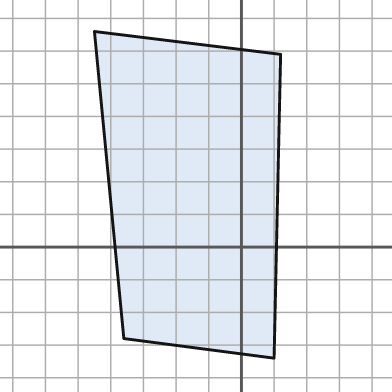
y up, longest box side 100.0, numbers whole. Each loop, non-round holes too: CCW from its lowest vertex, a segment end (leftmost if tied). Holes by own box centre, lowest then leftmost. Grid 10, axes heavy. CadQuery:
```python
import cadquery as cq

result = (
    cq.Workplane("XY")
    .moveTo(10.0, -34.0)
    .lineTo(12.0, 59.0)
    .lineTo(-45.0, 66.0)
    .lineTo(-36.0, -28.0)
    .close()
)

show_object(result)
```